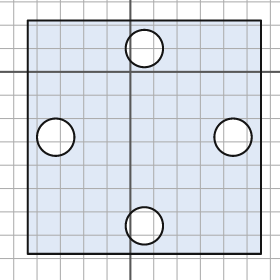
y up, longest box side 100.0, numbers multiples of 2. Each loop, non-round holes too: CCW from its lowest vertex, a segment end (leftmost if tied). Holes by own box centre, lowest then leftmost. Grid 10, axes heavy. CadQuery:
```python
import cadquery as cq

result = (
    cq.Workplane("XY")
    .moveTo(-44.0, -78.0)
    .lineTo(56.0, -78.0)
    .lineTo(56.0, 22.0)
    .lineTo(-44.0, 22.0)
    .close()
    .moveTo(6.0, -66.0)
    .circle(8.0)
    .moveTo(-32.0, -28.0)
    .circle(8.0)
    .moveTo(44.0, -28.0)
    .circle(8.0)
    .moveTo(6.0, 10.0)
    .circle(8.0)
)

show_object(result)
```